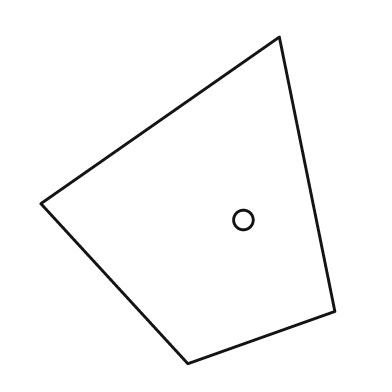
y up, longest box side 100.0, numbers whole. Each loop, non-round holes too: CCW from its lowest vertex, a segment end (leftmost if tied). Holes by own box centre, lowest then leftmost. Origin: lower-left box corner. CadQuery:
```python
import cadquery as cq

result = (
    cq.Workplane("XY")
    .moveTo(45.0, 0.0)
    .lineTo(90.0, 16.0)
    .lineTo(73.0, 100.0)
    .lineTo(0.0, 49.0)
    .close()
    .moveTo(62.0, 44.0)
    .circle(3.0)
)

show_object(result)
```